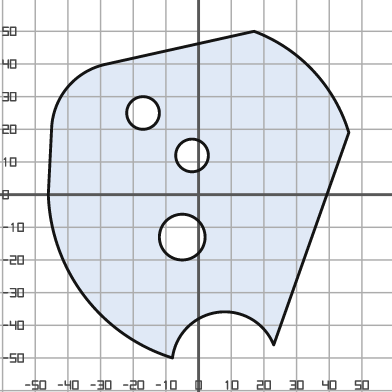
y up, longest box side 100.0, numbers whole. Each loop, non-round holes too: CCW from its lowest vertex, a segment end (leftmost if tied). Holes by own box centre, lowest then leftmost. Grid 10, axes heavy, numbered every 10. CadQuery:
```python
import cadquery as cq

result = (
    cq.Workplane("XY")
    .moveTo(-8.0, -50.0)
    .threePointArc((6.0, -36.0), (23.0, -46.0))
    .lineTo(46.0, 19.0)
    .threePointArc((35.0, 38.0), (17.0, 50.0))
    .lineTo(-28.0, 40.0)
    .threePointArc((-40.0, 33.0), (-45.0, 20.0))
    .lineTo(-46.0, 0.0)
    .threePointArc((-35.0, -31.0), (-8.0, -50.0))
    .close()
    .moveTo(-5.0, -13.0)
    .circle(7.0)
    .moveTo(-2.0, 12.0)
    .circle(5.0)
    .moveTo(-17.0, 25.0)
    .circle(5.0)
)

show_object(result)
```